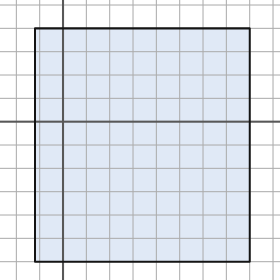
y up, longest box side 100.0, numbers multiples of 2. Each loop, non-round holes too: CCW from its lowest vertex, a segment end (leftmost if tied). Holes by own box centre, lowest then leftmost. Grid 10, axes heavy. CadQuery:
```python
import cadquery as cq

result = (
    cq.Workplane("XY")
    .moveTo(-12.0, -60.0)
    .lineTo(80.0, -60.0)
    .lineTo(80.0, 40.0)
    .lineTo(-12.0, 40.0)
    .close()
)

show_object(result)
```